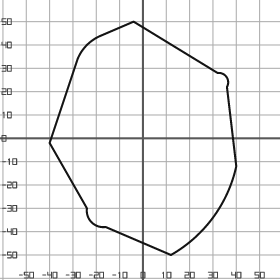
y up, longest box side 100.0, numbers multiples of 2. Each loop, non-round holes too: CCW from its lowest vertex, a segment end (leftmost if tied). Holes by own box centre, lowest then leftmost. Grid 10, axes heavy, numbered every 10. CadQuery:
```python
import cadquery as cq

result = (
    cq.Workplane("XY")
    .moveTo(12.0, -50.0)
    .threePointArc((30.0, -34.0), (40.0, -12.0))
    .lineTo(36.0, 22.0)
    .threePointArc((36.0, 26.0), (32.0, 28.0))
    .lineTo(-4.0, 50.0)
    .lineTo(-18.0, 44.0)
    .threePointArc((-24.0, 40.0), (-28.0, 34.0))
    .lineTo(-40.0, -2.0)
    .lineTo(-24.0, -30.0)
    .threePointArc((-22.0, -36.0), (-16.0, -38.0))
    .close()
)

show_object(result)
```